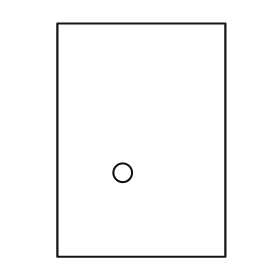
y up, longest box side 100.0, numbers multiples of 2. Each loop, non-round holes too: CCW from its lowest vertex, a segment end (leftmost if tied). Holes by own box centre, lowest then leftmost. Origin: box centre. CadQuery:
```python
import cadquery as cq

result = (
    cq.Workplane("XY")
    .moveTo(-36.0, -50.0)
    .lineTo(36.0, -50.0)
    .lineTo(36.0, 50.0)
    .lineTo(-36.0, 50.0)
    .close()
    .moveTo(-8.0, -14.0)
    .circle(4.0)
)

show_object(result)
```